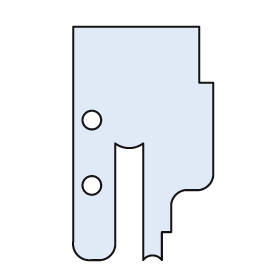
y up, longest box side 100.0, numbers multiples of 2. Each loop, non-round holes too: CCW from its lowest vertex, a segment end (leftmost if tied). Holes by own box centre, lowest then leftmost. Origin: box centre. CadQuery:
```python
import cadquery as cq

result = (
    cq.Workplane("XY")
    .moveTo(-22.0, -50.0)
    .lineTo(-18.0, -50.0)
    .threePointArc((-14.0, -48.0), (-12.0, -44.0))
    .lineTo(-12.0, 0.0)
    .threePointArc((-6.0, -2.0), (0.0, 0.0))
    .lineTo(0.0, -50.0)
    .threePointArc((4.0, -48.0), (8.0, -50.0))
    .lineTo(8.0, -38.0)
    .lineTo(12.0, -38.0)
    .lineTo(12.0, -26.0)
    .threePointArc((14.0, -22.0), (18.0, -20.0))
    .lineTo(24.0, -20.0)
    .threePointArc((28.0, -18.0), (30.0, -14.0))
    .lineTo(30.0, 26.0)
    .lineTo(24.0, 26.0)
    .lineTo(24.0, 50.0)
    .lineTo(-30.0, 50.0)
    .lineTo(-30.0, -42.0)
    .threePointArc((-28.0, -48.0), (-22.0, -50.0))
    .close()
    .moveTo(-22.0, -18.0)
    .circle(4.0)
    .moveTo(-22.0, 10.0)
    .circle(4.0)
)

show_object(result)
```